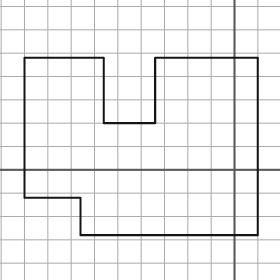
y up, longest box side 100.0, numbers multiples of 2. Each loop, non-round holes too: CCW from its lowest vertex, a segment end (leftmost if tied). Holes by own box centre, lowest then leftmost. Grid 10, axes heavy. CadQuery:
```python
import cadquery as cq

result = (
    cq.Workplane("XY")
    .moveTo(-66.0, -28.0)
    .lineTo(10.0, -28.0)
    .lineTo(10.0, 48.0)
    .lineTo(-34.0, 48.0)
    .lineTo(-34.0, 20.0)
    .lineTo(-56.0, 20.0)
    .lineTo(-56.0, 48.0)
    .lineTo(-90.0, 48.0)
    .lineTo(-90.0, -12.0)
    .lineTo(-66.0, -12.0)
    .close()
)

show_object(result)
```